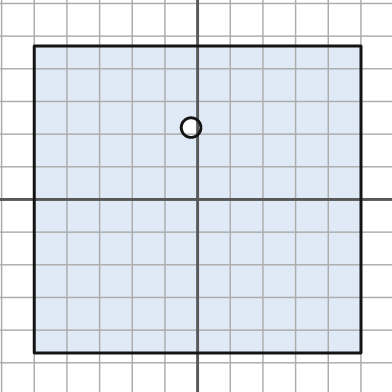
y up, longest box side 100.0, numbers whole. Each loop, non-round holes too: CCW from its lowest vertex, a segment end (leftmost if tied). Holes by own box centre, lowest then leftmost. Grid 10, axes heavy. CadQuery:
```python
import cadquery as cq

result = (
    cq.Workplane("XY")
    .moveTo(-50.0, -47.0)
    .lineTo(50.0, -47.0)
    .lineTo(50.0, 47.0)
    .lineTo(-50.0, 47.0)
    .close()
    .moveTo(-2.0, 22.0)
    .circle(3.0)
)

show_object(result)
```